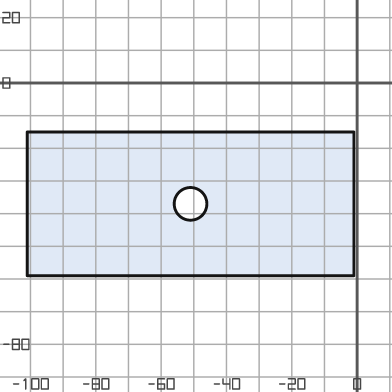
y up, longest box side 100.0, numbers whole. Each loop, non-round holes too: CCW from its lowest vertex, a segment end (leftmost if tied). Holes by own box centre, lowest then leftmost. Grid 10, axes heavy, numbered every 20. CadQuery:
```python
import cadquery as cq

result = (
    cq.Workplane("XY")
    .moveTo(-101.0, -59.0)
    .lineTo(-1.0, -59.0)
    .lineTo(-1.0, -15.0)
    .lineTo(-101.0, -15.0)
    .close()
    .moveTo(-51.0, -37.0)
    .circle(5.0)
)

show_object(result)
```